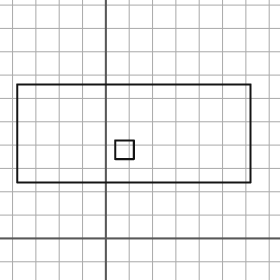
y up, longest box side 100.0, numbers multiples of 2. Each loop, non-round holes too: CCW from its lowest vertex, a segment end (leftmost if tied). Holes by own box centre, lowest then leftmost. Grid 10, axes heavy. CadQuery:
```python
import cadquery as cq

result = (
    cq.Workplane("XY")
    .moveTo(-38.0, 24.0)
    .lineTo(62.0, 24.0)
    .lineTo(62.0, 66.0)
    .lineTo(-38.0, 66.0)
    .close()
    .moveTo(4.0, 34.0)
    .lineTo(12.0, 34.0)
    .lineTo(12.0, 42.0)
    .lineTo(4.0, 42.0)
    .close()
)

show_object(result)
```